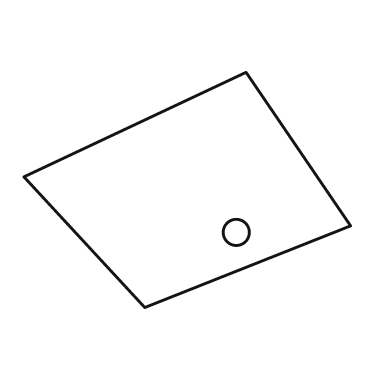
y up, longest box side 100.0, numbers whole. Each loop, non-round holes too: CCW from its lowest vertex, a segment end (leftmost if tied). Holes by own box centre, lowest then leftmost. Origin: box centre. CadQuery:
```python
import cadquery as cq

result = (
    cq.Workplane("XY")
    .moveTo(-13.0, -36.0)
    .lineTo(50.0, -11.0)
    .lineTo(18.0, 36.0)
    .lineTo(-50.0, 4.0)
    .close()
    .moveTo(15.0, -13.0)
    .circle(4.0)
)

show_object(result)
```